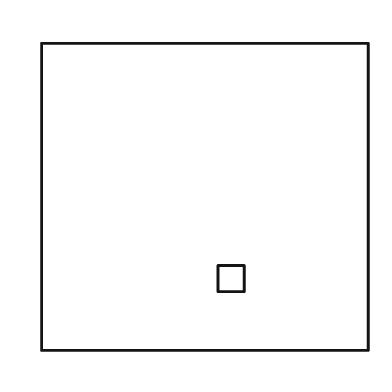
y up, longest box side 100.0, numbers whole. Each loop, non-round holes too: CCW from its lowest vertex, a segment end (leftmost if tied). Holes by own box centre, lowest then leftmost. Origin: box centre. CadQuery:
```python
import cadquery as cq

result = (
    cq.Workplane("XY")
    .moveTo(-50.0, -47.0)
    .lineTo(50.0, -47.0)
    .lineTo(50.0, 47.0)
    .lineTo(-50.0, 47.0)
    .close()
    .moveTo(4.0, -29.0)
    .lineTo(12.0, -29.0)
    .lineTo(12.0, -21.0)
    .lineTo(4.0, -21.0)
    .close()
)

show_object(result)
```